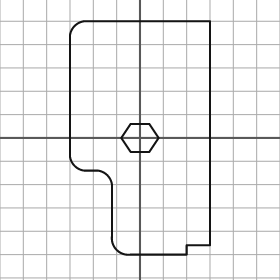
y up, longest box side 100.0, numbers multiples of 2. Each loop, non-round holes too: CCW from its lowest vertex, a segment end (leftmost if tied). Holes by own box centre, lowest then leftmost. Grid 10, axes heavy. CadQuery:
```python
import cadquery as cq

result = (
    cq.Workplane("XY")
    .moveTo(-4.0, -50.0)
    .lineTo(20.0, -50.0)
    .lineTo(20.0, -46.0)
    .lineTo(30.0, -46.0)
    .lineTo(30.0, 50.0)
    .lineTo(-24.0, 50.0)
    .threePointArc((-28.0, 48.0), (-30.0, 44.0))
    .lineTo(-30.0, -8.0)
    .threePointArc((-28.0, -12.0), (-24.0, -14.0))
    .lineTo(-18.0, -14.0)
    .threePointArc((-14.0, -16.0), (-12.0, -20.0))
    .lineTo(-12.0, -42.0)
    .threePointArc((-10.0, -48.0), (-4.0, -50.0))
    .close()
    .moveTo(-4.0, -6.0)
    .lineTo(4.0, -6.0)
    .lineTo(8.0, 0.0)
    .lineTo(4.0, 6.0)
    .lineTo(-4.0, 6.0)
    .lineTo(-8.0, 0.0)
    .close()
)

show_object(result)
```